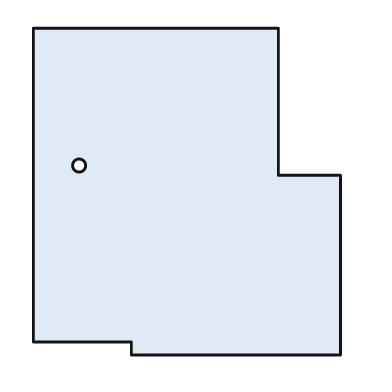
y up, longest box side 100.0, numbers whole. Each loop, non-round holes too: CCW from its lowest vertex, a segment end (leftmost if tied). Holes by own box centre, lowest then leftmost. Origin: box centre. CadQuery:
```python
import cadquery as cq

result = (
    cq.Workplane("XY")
    .moveTo(-17.0, -50.0)
    .lineTo(47.0, -50.0)
    .lineTo(47.0, 5.0)
    .lineTo(28.0, 5.0)
    .lineTo(28.0, 50.0)
    .lineTo(-47.0, 50.0)
    .lineTo(-47.0, -46.0)
    .lineTo(-17.0, -46.0)
    .close()
    .moveTo(-33.0, 8.0)
    .circle(2.0)
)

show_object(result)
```